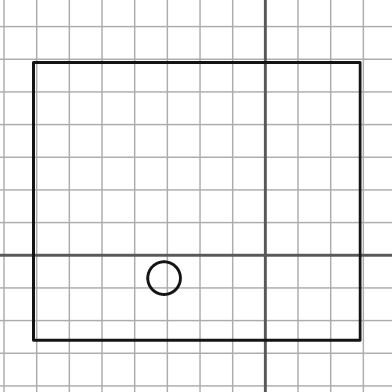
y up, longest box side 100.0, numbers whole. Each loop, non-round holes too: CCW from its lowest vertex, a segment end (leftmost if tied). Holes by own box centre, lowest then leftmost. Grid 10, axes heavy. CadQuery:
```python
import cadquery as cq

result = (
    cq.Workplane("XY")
    .moveTo(-71.0, -26.0)
    .lineTo(29.0, -26.0)
    .lineTo(29.0, 59.0)
    .lineTo(-71.0, 59.0)
    .close()
    .moveTo(-31.0, -7.0)
    .circle(5.0)
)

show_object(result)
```